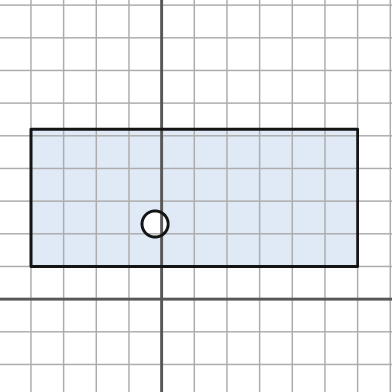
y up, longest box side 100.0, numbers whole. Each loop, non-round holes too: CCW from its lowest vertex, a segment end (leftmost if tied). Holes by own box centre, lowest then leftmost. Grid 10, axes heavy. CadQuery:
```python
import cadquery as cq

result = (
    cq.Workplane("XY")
    .moveTo(-40.0, 10.0)
    .lineTo(60.0, 10.0)
    .lineTo(60.0, 52.0)
    .lineTo(-40.0, 52.0)
    .close()
    .moveTo(-2.0, 23.0)
    .circle(4.0)
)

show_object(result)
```